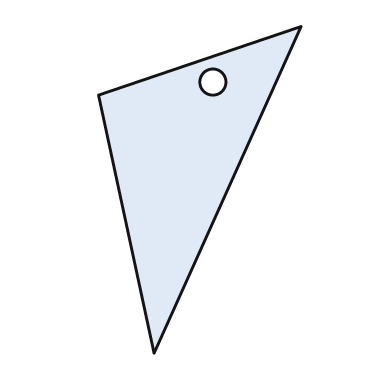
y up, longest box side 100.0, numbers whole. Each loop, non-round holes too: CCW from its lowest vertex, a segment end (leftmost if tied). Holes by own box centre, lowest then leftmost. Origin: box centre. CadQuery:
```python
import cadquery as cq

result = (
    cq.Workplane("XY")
    .moveTo(-14.0, -50.0)
    .lineTo(31.0, 50.0)
    .lineTo(-31.0, 29.0)
    .close()
    .moveTo(4.0, 33.0)
    .circle(4.0)
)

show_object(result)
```